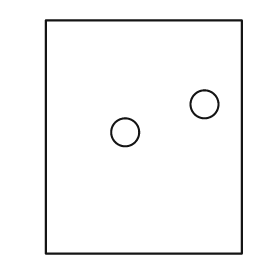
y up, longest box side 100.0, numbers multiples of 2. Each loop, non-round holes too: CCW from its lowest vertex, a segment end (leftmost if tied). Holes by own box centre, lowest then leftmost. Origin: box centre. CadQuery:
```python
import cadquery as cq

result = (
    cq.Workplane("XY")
    .moveTo(-42.0, -50.0)
    .lineTo(42.0, -50.0)
    .lineTo(42.0, 50.0)
    .lineTo(-42.0, 50.0)
    .close()
    .moveTo(-8.0, 2.0)
    .circle(6.0)
    .moveTo(26.0, 14.0)
    .circle(6.0)
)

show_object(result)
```